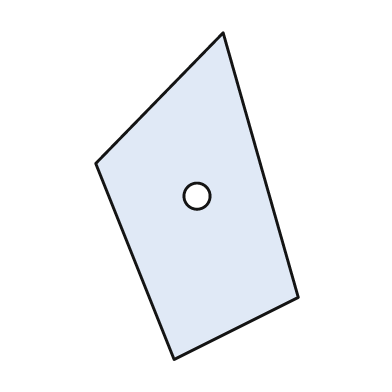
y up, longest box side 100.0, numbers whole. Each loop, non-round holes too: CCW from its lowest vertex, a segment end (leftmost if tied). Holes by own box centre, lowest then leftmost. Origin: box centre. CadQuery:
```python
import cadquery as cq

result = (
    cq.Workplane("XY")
    .moveTo(-7.0, -50.0)
    .lineTo(31.0, -31.0)
    .lineTo(8.0, 50.0)
    .lineTo(-31.0, 10.0)
    .close()
    .moveTo(0.0, 0.0)
    .circle(4.0)
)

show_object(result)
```